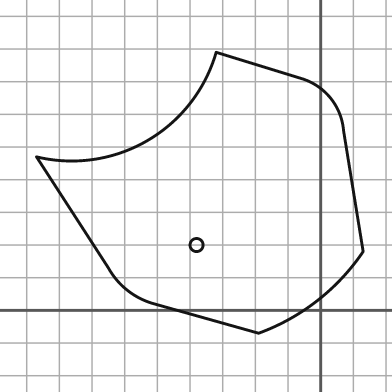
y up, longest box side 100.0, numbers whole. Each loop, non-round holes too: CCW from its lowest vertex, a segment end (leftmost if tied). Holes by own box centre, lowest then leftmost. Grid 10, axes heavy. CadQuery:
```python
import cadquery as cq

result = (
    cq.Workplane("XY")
    .moveTo(-19.0, -7.0)
    .threePointArc((-1.0, 3.0), (13.0, 18.0))
    .lineTo(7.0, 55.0)
    .threePointArc((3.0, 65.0), (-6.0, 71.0))
    .lineTo(-32.0, 79.0)
    .threePointArc((-53.0, 52.0), (-87.0, 47.0))
    .lineTo(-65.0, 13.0)
    .threePointArc((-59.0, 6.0), (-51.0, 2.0))
    .close()
    .moveTo(-38.0, 20.0)
    .circle(2.0)
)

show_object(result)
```